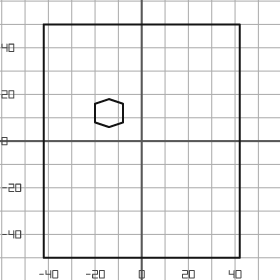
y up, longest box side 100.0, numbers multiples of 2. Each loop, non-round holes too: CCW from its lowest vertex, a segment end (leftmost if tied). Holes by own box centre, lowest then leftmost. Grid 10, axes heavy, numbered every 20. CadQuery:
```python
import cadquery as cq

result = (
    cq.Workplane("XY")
    .moveTo(-42.0, -50.0)
    .lineTo(42.0, -50.0)
    .lineTo(42.0, 50.0)
    .lineTo(-42.0, 50.0)
    .close()
    .moveTo(-14.0, 6.0)
    .lineTo(-8.0, 8.0)
    .lineTo(-8.0, 16.0)
    .lineTo(-14.0, 18.0)
    .lineTo(-20.0, 16.0)
    .lineTo(-20.0, 8.0)
    .close()
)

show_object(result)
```